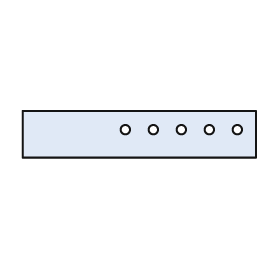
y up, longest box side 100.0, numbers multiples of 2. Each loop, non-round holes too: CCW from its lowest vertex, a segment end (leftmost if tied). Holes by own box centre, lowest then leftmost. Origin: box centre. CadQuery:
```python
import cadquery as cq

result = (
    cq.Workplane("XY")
    .moveTo(-50.0, -10.0)
    .lineTo(50.0, -10.0)
    .lineTo(50.0, 10.0)
    .lineTo(-50.0, 10.0)
    .close()
    .moveTo(-6.0, 2.0)
    .circle(2.0)
    .moveTo(6.0, 2.0)
    .circle(2.0)
    .moveTo(18.0, 2.0)
    .circle(2.0)
    .moveTo(30.0, 2.0)
    .circle(2.0)
    .moveTo(42.0, 2.0)
    .circle(2.0)
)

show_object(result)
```